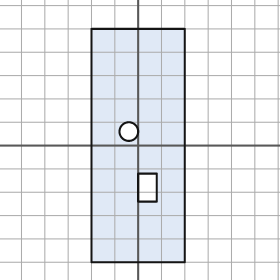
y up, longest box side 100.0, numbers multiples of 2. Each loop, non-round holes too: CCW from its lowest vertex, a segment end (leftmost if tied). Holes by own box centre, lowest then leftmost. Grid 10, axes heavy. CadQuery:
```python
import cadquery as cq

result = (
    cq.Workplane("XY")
    .moveTo(-20.0, -50.0)
    .lineTo(20.0, -50.0)
    .lineTo(20.0, 50.0)
    .lineTo(-20.0, 50.0)
    .close()
    .moveTo(0.0, -24.0)
    .lineTo(8.0, -24.0)
    .lineTo(8.0, -12.0)
    .lineTo(0.0, -12.0)
    .close()
    .moveTo(-4.0, 6.0)
    .circle(4.0)
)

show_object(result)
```